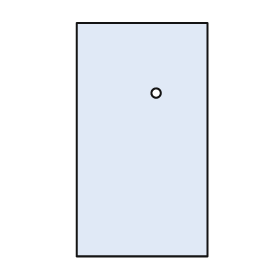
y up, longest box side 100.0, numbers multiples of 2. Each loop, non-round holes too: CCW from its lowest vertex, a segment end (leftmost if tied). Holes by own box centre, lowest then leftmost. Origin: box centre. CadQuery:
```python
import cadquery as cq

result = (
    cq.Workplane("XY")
    .moveTo(-28.0, -50.0)
    .lineTo(28.0, -50.0)
    .lineTo(28.0, 50.0)
    .lineTo(-28.0, 50.0)
    .close()
    .moveTo(6.0, 20.0)
    .circle(2.0)
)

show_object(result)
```